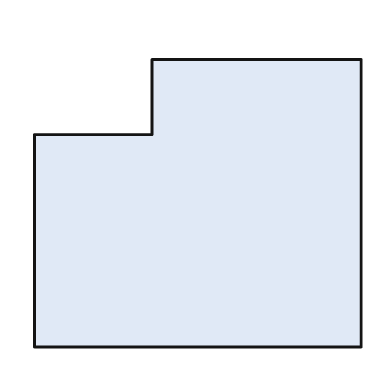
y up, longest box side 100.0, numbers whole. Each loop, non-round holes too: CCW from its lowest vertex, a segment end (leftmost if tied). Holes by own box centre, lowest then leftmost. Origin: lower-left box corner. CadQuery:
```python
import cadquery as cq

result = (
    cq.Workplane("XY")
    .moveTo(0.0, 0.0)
    .lineTo(100.0, 0.0)
    .lineTo(100.0, 88.0)
    .lineTo(36.0, 88.0)
    .lineTo(36.0, 65.0)
    .lineTo(0.0, 65.0)
    .close()
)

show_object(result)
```